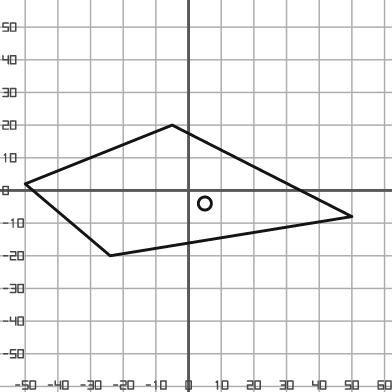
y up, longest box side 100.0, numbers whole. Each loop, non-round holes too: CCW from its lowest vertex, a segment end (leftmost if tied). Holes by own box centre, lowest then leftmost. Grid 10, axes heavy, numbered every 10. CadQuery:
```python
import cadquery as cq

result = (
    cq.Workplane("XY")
    .moveTo(-24.0, -20.0)
    .lineTo(50.0, -8.0)
    .lineTo(-5.0, 20.0)
    .lineTo(-50.0, 2.0)
    .close()
    .moveTo(5.0, -4.0)
    .circle(2.0)
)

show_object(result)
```